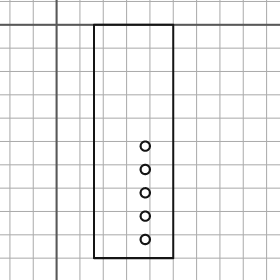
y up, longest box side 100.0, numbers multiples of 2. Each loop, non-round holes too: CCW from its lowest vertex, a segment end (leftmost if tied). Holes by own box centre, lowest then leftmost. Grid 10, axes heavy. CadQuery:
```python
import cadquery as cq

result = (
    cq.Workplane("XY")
    .moveTo(16.0, -100.0)
    .lineTo(50.0, -100.0)
    .lineTo(50.0, 0.0)
    .lineTo(16.0, 0.0)
    .close()
    .moveTo(38.0, -92.0)
    .circle(2.0)
    .moveTo(38.0, -82.0)
    .circle(2.0)
    .moveTo(38.0, -72.0)
    .circle(2.0)
    .moveTo(38.0, -62.0)
    .circle(2.0)
    .moveTo(38.0, -52.0)
    .circle(2.0)
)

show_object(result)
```